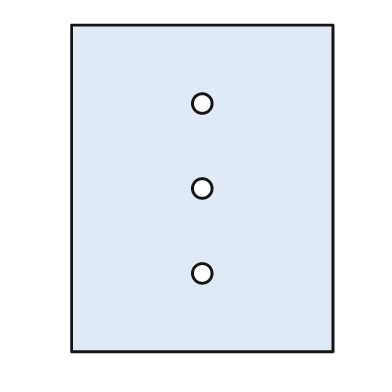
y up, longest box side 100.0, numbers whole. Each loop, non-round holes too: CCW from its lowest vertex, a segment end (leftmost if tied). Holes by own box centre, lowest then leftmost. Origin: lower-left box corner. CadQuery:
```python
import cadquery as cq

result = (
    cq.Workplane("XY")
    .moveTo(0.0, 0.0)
    .lineTo(80.0, 0.0)
    .lineTo(80.0, 100.0)
    .lineTo(0.0, 100.0)
    .close()
    .moveTo(40.0, 24.0)
    .circle(3.0)
    .moveTo(40.0, 50.0)
    .circle(3.0)
    .moveTo(40.0, 76.0)
    .circle(3.0)
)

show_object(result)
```